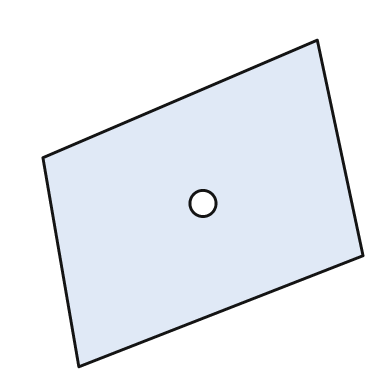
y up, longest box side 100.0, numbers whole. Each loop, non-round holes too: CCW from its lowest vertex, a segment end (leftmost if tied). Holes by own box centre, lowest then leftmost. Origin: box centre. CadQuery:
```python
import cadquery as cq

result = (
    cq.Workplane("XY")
    .moveTo(-38.0, -50.0)
    .lineTo(49.0, -16.0)
    .lineTo(35.0, 50.0)
    .lineTo(-49.0, 14.0)
    .close()
    .moveTo(0.0, 0.0)
    .circle(4.0)
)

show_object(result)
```